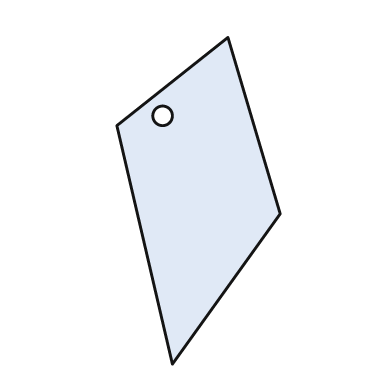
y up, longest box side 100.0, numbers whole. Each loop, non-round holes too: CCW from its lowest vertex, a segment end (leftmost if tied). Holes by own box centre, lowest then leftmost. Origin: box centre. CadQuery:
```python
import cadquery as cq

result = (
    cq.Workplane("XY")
    .moveTo(-8.0, -50.0)
    .lineTo(25.0, -4.0)
    .lineTo(9.0, 50.0)
    .lineTo(-25.0, 23.0)
    .close()
    .moveTo(-11.0, 26.0)
    .circle(3.0)
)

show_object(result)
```